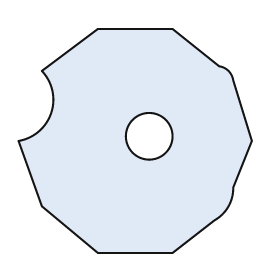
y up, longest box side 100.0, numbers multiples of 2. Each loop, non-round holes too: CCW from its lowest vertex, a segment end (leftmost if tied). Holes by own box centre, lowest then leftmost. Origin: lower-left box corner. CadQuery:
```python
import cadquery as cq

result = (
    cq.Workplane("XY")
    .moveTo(34.0, 0.0)
    .lineTo(66.0, 0.0)
    .lineTo(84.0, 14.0)
    .threePointArc((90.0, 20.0), (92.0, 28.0))
    .lineTo(100.0, 48.0)
    .lineTo(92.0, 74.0)
    .threePointArc((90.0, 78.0), (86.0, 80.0))
    .lineTo(66.0, 96.0)
    .lineTo(34.0, 96.0)
    .lineTo(10.0, 78.0)
    .threePointArc((14.0, 60.0), (0.0, 48.0))
    .lineTo(10.0, 20.0)
    .close()
    .moveTo(56.0, 50.0)
    .circle(10.0)
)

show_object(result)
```